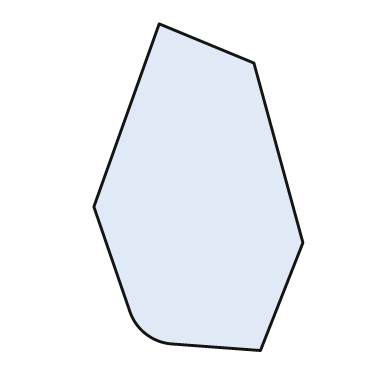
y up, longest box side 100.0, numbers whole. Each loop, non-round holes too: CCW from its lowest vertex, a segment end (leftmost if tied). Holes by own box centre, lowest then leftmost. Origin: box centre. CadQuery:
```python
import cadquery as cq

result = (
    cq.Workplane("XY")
    .moveTo(19.0, -50.0)
    .lineTo(32.0, -17.0)
    .lineTo(17.0, 38.0)
    .lineTo(-12.0, 50.0)
    .lineTo(-32.0, -6.0)
    .lineTo(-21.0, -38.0)
    .threePointArc((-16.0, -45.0), (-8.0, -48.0))
    .close()
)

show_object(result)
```